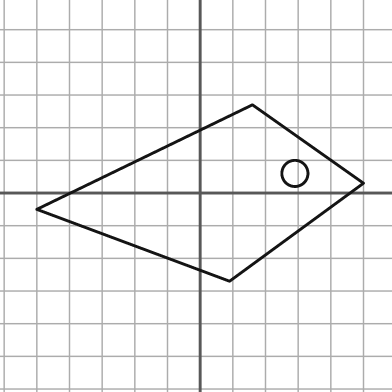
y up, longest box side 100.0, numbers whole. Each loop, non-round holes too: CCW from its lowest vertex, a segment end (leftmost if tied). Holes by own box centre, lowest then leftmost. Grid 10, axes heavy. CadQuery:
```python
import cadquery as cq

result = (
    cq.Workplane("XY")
    .moveTo(9.0, -27.0)
    .lineTo(50.0, 3.0)
    .lineTo(16.0, 27.0)
    .lineTo(-50.0, -5.0)
    .close()
    .moveTo(29.0, 6.0)
    .circle(4.0)
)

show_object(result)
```